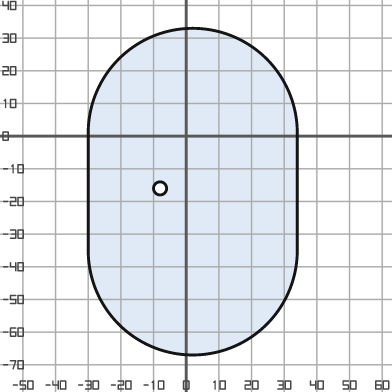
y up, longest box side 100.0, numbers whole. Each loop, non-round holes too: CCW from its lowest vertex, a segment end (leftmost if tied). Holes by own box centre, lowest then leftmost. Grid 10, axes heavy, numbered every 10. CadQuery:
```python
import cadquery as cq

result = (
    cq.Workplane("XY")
    .moveTo(-30.0, -35.0)
    .threePointArc((2.0, -67.0), (34.0, -35.0))
    .lineTo(34.0, 1.0)
    .threePointArc((2.0, 33.0), (-30.0, 1.0))
    .close()
    .moveTo(-8.0, -16.0)
    .circle(2.0)
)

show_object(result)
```